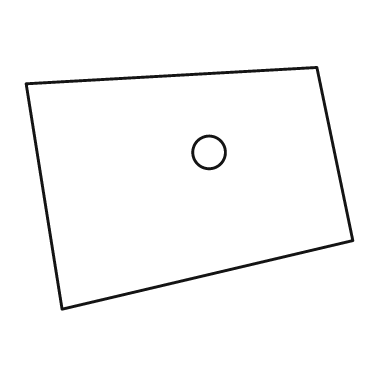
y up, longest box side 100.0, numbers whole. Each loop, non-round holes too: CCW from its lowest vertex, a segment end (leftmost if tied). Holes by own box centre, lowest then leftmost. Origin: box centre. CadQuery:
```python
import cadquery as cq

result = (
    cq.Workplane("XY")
    .moveTo(-39.0, -37.0)
    .lineTo(50.0, -16.0)
    .lineTo(39.0, 37.0)
    .lineTo(-50.0, 32.0)
    .close()
    .moveTo(6.0, 11.0)
    .circle(5.0)
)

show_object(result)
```